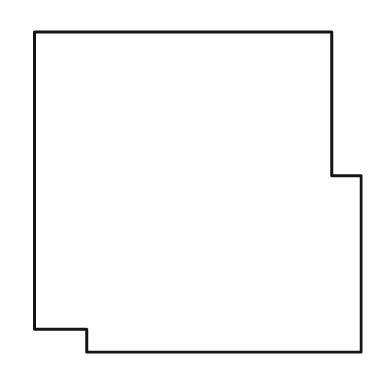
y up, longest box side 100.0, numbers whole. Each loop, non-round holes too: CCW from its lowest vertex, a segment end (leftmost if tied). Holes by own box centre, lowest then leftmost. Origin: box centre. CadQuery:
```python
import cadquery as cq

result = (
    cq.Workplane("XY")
    .moveTo(-34.0, -49.0)
    .lineTo(50.0, -49.0)
    .lineTo(50.0, 5.0)
    .lineTo(41.0, 5.0)
    .lineTo(41.0, 49.0)
    .lineTo(-50.0, 49.0)
    .lineTo(-50.0, -42.0)
    .lineTo(-34.0, -42.0)
    .close()
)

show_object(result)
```